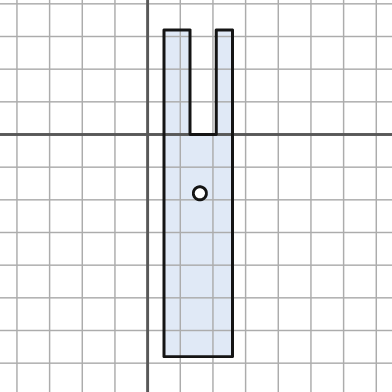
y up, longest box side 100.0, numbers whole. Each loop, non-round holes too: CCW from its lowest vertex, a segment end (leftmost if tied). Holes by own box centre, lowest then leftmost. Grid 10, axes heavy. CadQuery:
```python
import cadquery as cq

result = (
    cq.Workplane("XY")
    .moveTo(5.0, -68.0)
    .lineTo(26.0, -68.0)
    .lineTo(26.0, 32.0)
    .lineTo(21.0, 32.0)
    .lineTo(21.0, 0.0)
    .lineTo(13.0, 0.0)
    .lineTo(13.0, 32.0)
    .lineTo(5.0, 32.0)
    .close()
    .moveTo(16.0, -18.0)
    .circle(2.0)
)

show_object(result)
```